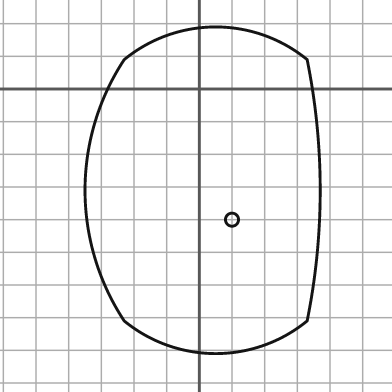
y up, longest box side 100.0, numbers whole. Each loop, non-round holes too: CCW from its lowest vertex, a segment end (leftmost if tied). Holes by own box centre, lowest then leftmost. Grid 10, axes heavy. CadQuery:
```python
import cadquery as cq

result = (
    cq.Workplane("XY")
    .moveTo(-23.0, -71.0)
    .threePointArc((5.0, -81.0), (33.0, -71.0))
    .threePointArc((37.0, -31.0), (33.0, 9.0))
    .threePointArc((5.0, 19.0), (-23.0, 9.0))
    .threePointArc((-35.0, -31.0), (-23.0, -71.0))
    .close()
    .moveTo(10.0, -40.0)
    .circle(2.0)
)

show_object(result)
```